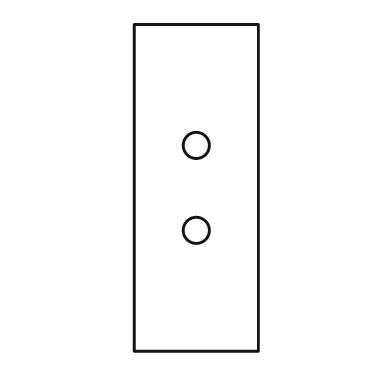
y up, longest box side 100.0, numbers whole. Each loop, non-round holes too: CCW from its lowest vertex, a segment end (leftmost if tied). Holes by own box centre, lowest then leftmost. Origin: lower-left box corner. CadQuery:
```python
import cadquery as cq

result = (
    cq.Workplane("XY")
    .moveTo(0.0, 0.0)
    .lineTo(38.0, 0.0)
    .lineTo(38.0, 100.0)
    .lineTo(0.0, 100.0)
    .close()
    .moveTo(19.0, 37.0)
    .circle(4.0)
    .moveTo(19.0, 63.0)
    .circle(4.0)
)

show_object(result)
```